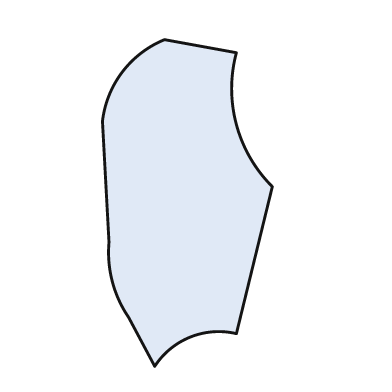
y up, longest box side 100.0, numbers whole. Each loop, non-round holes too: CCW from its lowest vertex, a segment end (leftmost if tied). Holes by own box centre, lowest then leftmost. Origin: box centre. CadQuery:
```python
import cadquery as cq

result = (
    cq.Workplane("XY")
    .moveTo(-10.0, -50.0)
    .threePointArc((1.0, -41.0), (15.0, -40.0))
    .lineTo(26.0, 5.0)
    .threePointArc((15.0, 24.0), (15.0, 46.0))
    .lineTo(-7.0, 50.0)
    .threePointArc((-20.0, 40.0), (-26.0, 25.0))
    .lineTo(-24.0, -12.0)
    .threePointArc((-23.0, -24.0), (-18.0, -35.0))
    .close()
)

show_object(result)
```